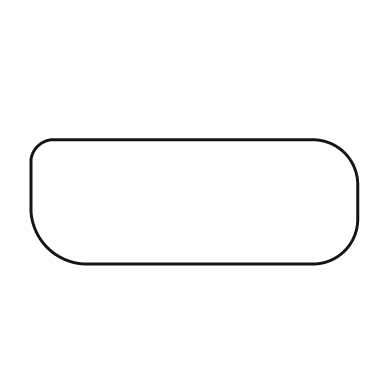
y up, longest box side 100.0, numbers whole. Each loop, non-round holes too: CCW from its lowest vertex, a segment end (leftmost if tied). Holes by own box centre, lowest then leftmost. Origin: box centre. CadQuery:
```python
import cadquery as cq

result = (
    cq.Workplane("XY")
    .moveTo(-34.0, -19.0)
    .lineTo(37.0, -19.0)
    .threePointArc((46.0, -15.0), (50.0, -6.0))
    .lineTo(50.0, 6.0)
    .threePointArc((46.0, 15.0), (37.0, 19.0))
    .lineTo(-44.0, 19.0)
    .threePointArc((-48.0, 17.0), (-50.0, 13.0))
    .lineTo(-50.0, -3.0)
    .threePointArc((-45.0, -14.0), (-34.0, -19.0))
    .close()
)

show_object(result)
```